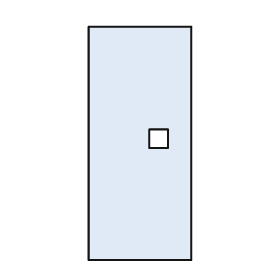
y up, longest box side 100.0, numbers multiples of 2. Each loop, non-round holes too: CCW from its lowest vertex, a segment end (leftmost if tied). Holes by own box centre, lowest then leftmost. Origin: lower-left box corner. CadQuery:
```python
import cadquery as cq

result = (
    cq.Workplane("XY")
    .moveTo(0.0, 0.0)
    .lineTo(44.0, 0.0)
    .lineTo(44.0, 100.0)
    .lineTo(0.0, 100.0)
    .close()
    .moveTo(26.0, 48.0)
    .lineTo(34.0, 48.0)
    .lineTo(34.0, 56.0)
    .lineTo(26.0, 56.0)
    .close()
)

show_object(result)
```